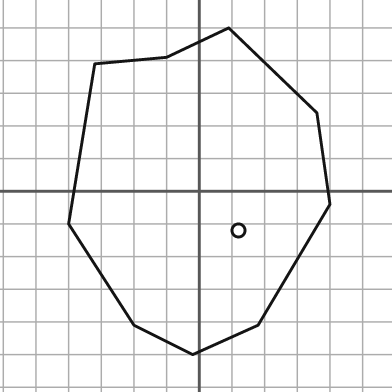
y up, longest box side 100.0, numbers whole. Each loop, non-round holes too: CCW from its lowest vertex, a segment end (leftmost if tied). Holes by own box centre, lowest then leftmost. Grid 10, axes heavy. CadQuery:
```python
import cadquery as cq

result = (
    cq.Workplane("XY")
    .moveTo(-2.0, -50.0)
    .lineTo(18.0, -41.0)
    .lineTo(40.0, -4.0)
    .lineTo(36.0, 24.0)
    .lineTo(9.0, 50.0)
    .lineTo(-10.0, 41.0)
    .lineTo(-32.0, 39.0)
    .lineTo(-40.0, -10.0)
    .lineTo(-20.0, -41.0)
    .close()
    .moveTo(12.0, -12.0)
    .circle(2.0)
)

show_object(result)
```